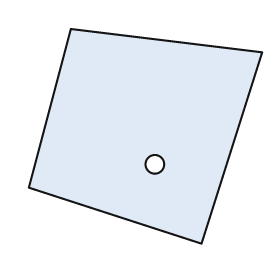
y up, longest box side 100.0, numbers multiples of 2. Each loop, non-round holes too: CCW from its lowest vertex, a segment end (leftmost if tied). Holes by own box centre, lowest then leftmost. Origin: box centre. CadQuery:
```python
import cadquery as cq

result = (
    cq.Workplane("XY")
    .moveTo(24.0, -46.0)
    .lineTo(50.0, 36.0)
    .lineTo(-32.0, 46.0)
    .lineTo(-50.0, -22.0)
    .close()
    .moveTo(4.0, -12.0)
    .circle(4.0)
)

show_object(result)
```